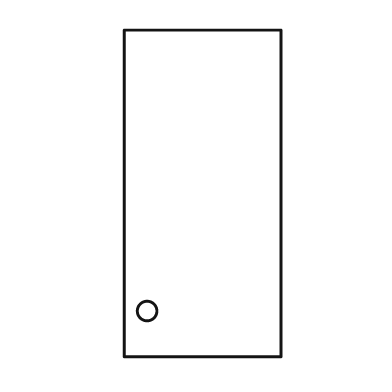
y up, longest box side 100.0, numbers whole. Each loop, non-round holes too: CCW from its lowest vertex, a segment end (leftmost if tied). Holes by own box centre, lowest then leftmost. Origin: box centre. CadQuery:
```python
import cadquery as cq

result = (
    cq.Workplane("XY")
    .moveTo(-24.0, -50.0)
    .lineTo(24.0, -50.0)
    .lineTo(24.0, 50.0)
    .lineTo(-24.0, 50.0)
    .close()
    .moveTo(-17.0, -36.0)
    .circle(3.0)
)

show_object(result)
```